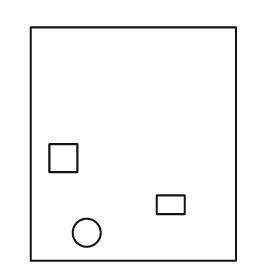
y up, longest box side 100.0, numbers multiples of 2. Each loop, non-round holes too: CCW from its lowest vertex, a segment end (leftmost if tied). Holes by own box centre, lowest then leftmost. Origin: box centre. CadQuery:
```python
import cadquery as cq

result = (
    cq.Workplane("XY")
    .moveTo(-44.0, -50.0)
    .lineTo(44.0, -50.0)
    .lineTo(44.0, 50.0)
    .lineTo(-44.0, 50.0)
    .close()
    .moveTo(-20.0, -38.0)
    .circle(6.0)
    .moveTo(10.0, -30.0)
    .lineTo(22.0, -30.0)
    .lineTo(22.0, -22.0)
    .lineTo(10.0, -22.0)
    .close()
    .moveTo(-36.0, -12.0)
    .lineTo(-24.0, -12.0)
    .lineTo(-24.0, 0.0)
    .lineTo(-36.0, 0.0)
    .close()
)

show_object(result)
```